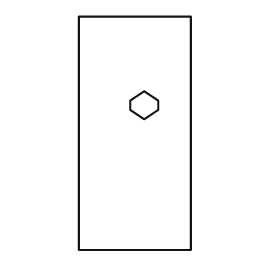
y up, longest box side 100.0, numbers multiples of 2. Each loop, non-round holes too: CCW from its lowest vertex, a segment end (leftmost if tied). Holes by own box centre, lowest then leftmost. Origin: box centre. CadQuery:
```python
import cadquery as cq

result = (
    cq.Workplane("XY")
    .moveTo(-24.0, -50.0)
    .lineTo(24.0, -50.0)
    .lineTo(24.0, 50.0)
    .lineTo(-24.0, 50.0)
    .close()
    .moveTo(4.0, 6.0)
    .lineTo(10.0, 10.0)
    .lineTo(10.0, 14.0)
    .lineTo(4.0, 18.0)
    .lineTo(-2.0, 14.0)
    .lineTo(-2.0, 10.0)
    .close()
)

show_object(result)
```